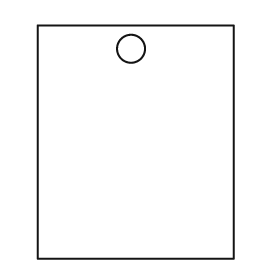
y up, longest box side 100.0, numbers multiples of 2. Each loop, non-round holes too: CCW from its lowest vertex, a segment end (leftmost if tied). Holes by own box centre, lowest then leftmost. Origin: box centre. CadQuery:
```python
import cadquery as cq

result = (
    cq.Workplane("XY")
    .moveTo(-42.0, -50.0)
    .lineTo(42.0, -50.0)
    .lineTo(42.0, 50.0)
    .lineTo(-42.0, 50.0)
    .close()
    .moveTo(-2.0, 40.0)
    .circle(6.0)
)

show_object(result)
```